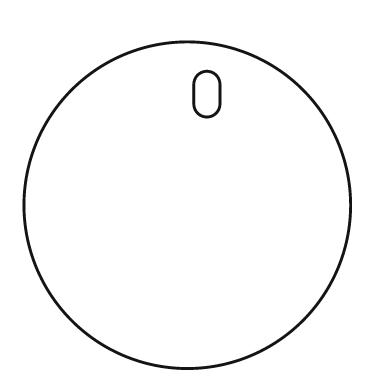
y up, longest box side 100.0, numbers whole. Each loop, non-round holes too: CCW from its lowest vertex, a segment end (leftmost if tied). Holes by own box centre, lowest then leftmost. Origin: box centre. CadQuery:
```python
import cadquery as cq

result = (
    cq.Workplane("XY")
    .moveTo(0.0, 0.0)
    .circle(50.0)
    .moveTo(2.0, 31.0)
    .threePointArc((6.0, 27.0), (10.0, 31.0))
    .lineTo(10.0, 37.0)
    .threePointArc((6.0, 41.0), (2.0, 37.0))
    .close()
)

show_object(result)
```